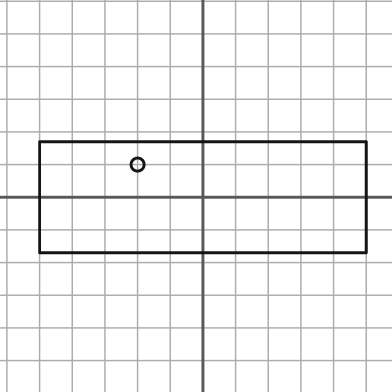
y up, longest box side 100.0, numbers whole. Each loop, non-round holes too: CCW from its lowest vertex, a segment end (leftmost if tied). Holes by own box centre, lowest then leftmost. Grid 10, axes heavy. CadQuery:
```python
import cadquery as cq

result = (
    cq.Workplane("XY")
    .moveTo(-50.0, -17.0)
    .lineTo(50.0, -17.0)
    .lineTo(50.0, 17.0)
    .lineTo(-50.0, 17.0)
    .close()
    .moveTo(-20.0, 10.0)
    .circle(2.0)
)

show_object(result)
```